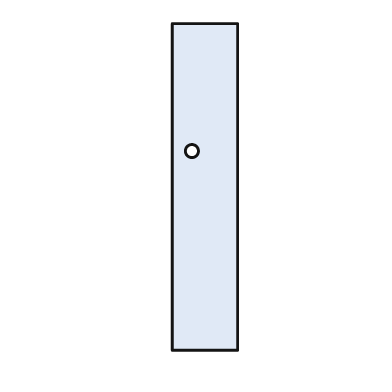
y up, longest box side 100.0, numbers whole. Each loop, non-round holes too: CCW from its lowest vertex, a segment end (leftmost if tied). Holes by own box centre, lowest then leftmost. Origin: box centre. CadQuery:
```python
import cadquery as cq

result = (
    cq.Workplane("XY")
    .moveTo(-10.0, -50.0)
    .lineTo(10.0, -50.0)
    .lineTo(10.0, 50.0)
    .lineTo(-10.0, 50.0)
    .close()
    .moveTo(-4.0, 11.0)
    .circle(2.0)
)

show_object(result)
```